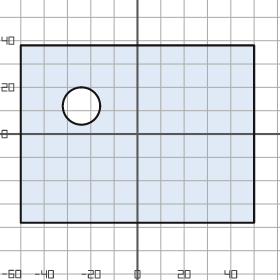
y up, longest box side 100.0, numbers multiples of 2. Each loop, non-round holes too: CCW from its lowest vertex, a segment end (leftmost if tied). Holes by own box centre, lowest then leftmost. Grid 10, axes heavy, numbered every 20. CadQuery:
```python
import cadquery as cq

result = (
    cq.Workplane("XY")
    .moveTo(-50.0, -38.0)
    .lineTo(50.0, -38.0)
    .lineTo(50.0, 38.0)
    .lineTo(-50.0, 38.0)
    .close()
    .moveTo(-24.0, 12.0)
    .circle(8.0)
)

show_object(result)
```